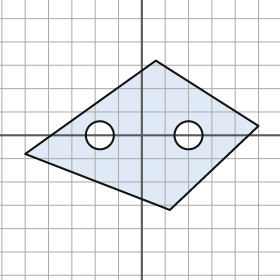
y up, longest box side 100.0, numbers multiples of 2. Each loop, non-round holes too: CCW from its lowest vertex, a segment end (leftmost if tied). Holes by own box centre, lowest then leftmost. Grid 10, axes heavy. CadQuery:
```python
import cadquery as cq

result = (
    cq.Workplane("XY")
    .moveTo(12.0, -32.0)
    .lineTo(50.0, 4.0)
    .lineTo(6.0, 32.0)
    .lineTo(-50.0, -8.0)
    .close()
    .moveTo(-18.0, 0.0)
    .circle(6.0)
    .moveTo(20.0, 0.0)
    .circle(6.0)
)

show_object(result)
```